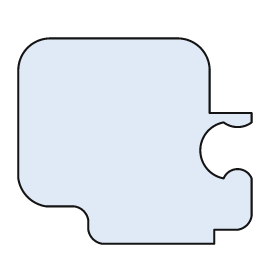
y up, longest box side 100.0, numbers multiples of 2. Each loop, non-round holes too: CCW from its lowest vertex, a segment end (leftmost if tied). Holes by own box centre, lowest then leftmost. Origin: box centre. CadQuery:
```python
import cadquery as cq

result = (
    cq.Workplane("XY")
    .moveTo(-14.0, -44.0)
    .lineTo(34.0, -44.0)
    .lineTo(34.0, -38.0)
    .lineTo(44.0, -38.0)
    .threePointArc((48.0, -36.0), (50.0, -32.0))
    .lineTo(50.0, -16.0)
    .threePointArc((44.0, -12.0), (38.0, -16.0))
    .threePointArc((28.0, -4.0), (38.0, 8.0))
    .threePointArc((44.0, 6.0), (50.0, 8.0))
    .lineTo(50.0, 12.0)
    .lineTo(32.0, 12.0)
    .lineTo(32.0, 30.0)
    .threePointArc((28.0, 40.0), (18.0, 44.0))
    .lineTo(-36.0, 44.0)
    .threePointArc((-46.0, 40.0), (-50.0, 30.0))
    .lineTo(-50.0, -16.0)
    .threePointArc((-46.0, -24.0), (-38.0, -28.0))
    .lineTo(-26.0, -28.0)
    .threePointArc((-22.0, -30.0), (-20.0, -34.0))
    .lineTo(-20.0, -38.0)
    .threePointArc((-18.0, -42.0), (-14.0, -44.0))
    .close()
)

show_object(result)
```